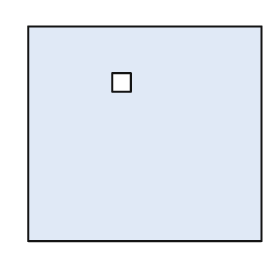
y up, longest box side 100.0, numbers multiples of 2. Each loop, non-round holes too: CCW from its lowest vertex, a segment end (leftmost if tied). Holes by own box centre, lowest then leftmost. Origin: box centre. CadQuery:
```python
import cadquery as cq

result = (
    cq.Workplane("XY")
    .moveTo(-50.0, -46.0)
    .lineTo(50.0, -46.0)
    .lineTo(50.0, 46.0)
    .lineTo(-50.0, 46.0)
    .close()
    .moveTo(-14.0, 18.0)
    .lineTo(-6.0, 18.0)
    .lineTo(-6.0, 26.0)
    .lineTo(-14.0, 26.0)
    .close()
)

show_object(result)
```